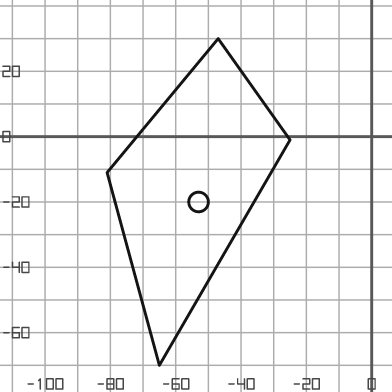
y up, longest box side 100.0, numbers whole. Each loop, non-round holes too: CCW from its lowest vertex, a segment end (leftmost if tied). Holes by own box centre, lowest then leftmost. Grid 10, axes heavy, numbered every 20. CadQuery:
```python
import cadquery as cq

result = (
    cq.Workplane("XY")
    .moveTo(-65.0, -70.0)
    .lineTo(-25.0, -1.0)
    .lineTo(-47.0, 30.0)
    .lineTo(-81.0, -11.0)
    .close()
    .moveTo(-53.0, -20.0)
    .circle(3.0)
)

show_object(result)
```